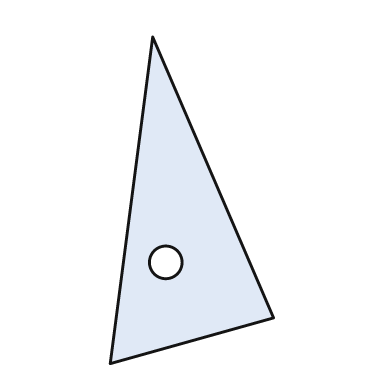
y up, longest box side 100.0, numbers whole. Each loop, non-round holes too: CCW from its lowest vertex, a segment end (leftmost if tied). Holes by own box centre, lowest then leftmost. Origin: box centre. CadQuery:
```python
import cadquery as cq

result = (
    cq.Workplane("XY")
    .moveTo(-25.0, -50.0)
    .lineTo(25.0, -36.0)
    .lineTo(-12.0, 50.0)
    .close()
    .moveTo(-8.0, -19.0)
    .circle(5.0)
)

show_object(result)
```